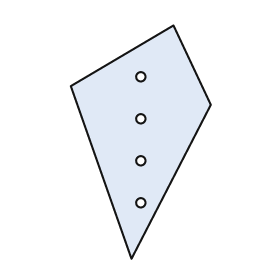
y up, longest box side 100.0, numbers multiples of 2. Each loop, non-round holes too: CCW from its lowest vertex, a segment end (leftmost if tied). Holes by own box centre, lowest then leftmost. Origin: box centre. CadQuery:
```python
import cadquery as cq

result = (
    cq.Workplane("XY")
    .moveTo(-4.0, -50.0)
    .lineTo(30.0, 16.0)
    .lineTo(14.0, 50.0)
    .lineTo(-30.0, 24.0)
    .close()
    .moveTo(0.0, -26.0)
    .circle(2.0)
    .moveTo(0.0, -8.0)
    .circle(2.0)
    .moveTo(0.0, 10.0)
    .circle(2.0)
    .moveTo(0.0, 28.0)
    .circle(2.0)
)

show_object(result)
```